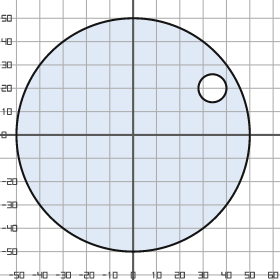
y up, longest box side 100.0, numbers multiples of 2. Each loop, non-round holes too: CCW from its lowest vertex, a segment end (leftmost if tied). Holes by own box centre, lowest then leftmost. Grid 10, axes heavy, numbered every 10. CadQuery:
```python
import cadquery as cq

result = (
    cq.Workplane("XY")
    .moveTo(0.0, 0.0)
    .circle(50.0)
    .moveTo(34.0, 20.0)
    .circle(6.0)
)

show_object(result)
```